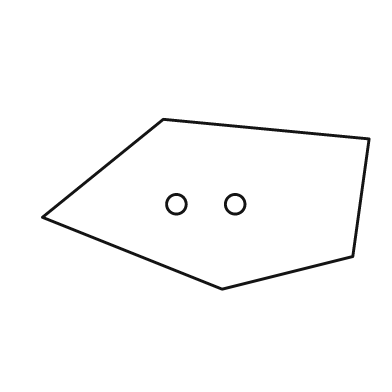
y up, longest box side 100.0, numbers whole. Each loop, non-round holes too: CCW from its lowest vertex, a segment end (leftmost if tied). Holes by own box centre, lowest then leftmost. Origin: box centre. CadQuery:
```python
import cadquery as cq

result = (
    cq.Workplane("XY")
    .moveTo(5.0, -26.0)
    .lineTo(45.0, -16.0)
    .lineTo(50.0, 20.0)
    .lineTo(-13.0, 26.0)
    .lineTo(-50.0, -4.0)
    .close()
    .moveTo(-9.0, 0.0)
    .circle(3.0)
    .moveTo(9.0, 0.0)
    .circle(3.0)
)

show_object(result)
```